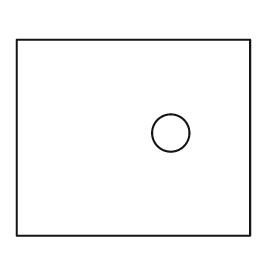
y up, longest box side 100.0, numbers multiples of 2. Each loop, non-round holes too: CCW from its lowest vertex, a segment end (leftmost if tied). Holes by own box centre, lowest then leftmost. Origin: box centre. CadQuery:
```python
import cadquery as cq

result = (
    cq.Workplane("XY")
    .moveTo(-50.0, -42.0)
    .lineTo(50.0, -42.0)
    .lineTo(50.0, 42.0)
    .lineTo(-50.0, 42.0)
    .close()
    .moveTo(16.0, 2.0)
    .circle(8.0)
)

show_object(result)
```